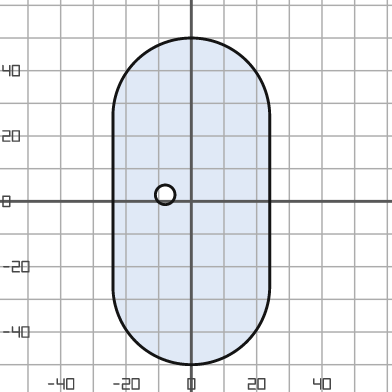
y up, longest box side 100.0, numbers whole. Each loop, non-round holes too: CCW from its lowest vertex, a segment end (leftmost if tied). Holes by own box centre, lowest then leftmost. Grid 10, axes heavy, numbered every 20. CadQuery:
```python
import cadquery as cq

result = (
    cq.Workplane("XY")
    .moveTo(-24.0, -26.0)
    .threePointArc((0.0, -50.0), (24.0, -26.0))
    .lineTo(24.0, 26.0)
    .threePointArc((0.0, 50.0), (-24.0, 26.0))
    .close()
    .moveTo(-8.0, 2.0)
    .circle(3.0)
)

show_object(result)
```